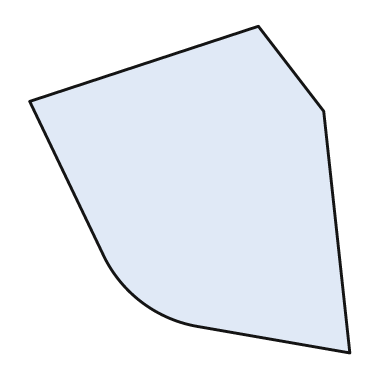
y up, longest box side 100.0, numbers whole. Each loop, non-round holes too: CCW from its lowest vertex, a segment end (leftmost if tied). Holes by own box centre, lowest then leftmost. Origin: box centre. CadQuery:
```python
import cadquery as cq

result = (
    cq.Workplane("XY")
    .moveTo(49.0, -50.0)
    .lineTo(41.0, 24.0)
    .lineTo(21.0, 50.0)
    .lineTo(-49.0, 27.0)
    .lineTo(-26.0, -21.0)
    .threePointArc((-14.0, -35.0), (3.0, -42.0))
    .close()
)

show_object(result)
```